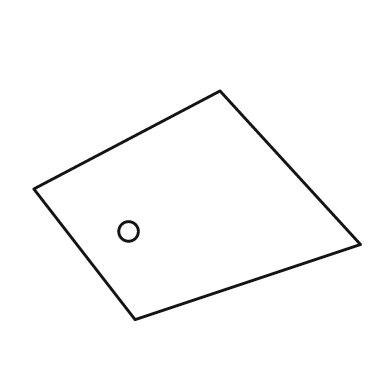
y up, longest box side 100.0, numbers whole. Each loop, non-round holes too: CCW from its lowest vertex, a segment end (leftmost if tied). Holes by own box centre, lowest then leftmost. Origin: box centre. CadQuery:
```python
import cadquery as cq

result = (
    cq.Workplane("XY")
    .moveTo(-19.0, -35.0)
    .lineTo(50.0, -12.0)
    .lineTo(7.0, 35.0)
    .lineTo(-50.0, 5.0)
    .close()
    .moveTo(-21.0, -8.0)
    .circle(3.0)
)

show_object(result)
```